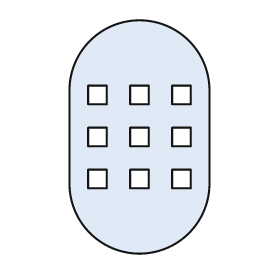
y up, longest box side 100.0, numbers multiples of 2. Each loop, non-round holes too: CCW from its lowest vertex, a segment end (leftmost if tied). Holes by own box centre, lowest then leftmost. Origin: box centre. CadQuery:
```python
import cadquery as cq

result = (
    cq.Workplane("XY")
    .moveTo(-30.0, -20.0)
    .threePointArc((0.0, -50.0), (30.0, -20.0))
    .lineTo(30.0, 20.0)
    .threePointArc((0.0, 50.0), (-30.0, 20.0))
    .close()
    .moveTo(-22.0, -22.0)
    .lineTo(-14.0, -22.0)
    .lineTo(-14.0, -14.0)
    .lineTo(-22.0, -14.0)
    .close()
    .moveTo(-4.0, -22.0)
    .lineTo(4.0, -22.0)
    .lineTo(4.0, -14.0)
    .lineTo(-4.0, -14.0)
    .close()
    .moveTo(14.0, -22.0)
    .lineTo(22.0, -22.0)
    .lineTo(22.0, -14.0)
    .lineTo(14.0, -14.0)
    .close()
    .moveTo(-22.0, -4.0)
    .lineTo(-14.0, -4.0)
    .lineTo(-14.0, 4.0)
    .lineTo(-22.0, 4.0)
    .close()
    .moveTo(-4.0, -4.0)
    .lineTo(4.0, -4.0)
    .lineTo(4.0, 4.0)
    .lineTo(-4.0, 4.0)
    .close()
    .moveTo(14.0, -4.0)
    .lineTo(22.0, -4.0)
    .lineTo(22.0, 4.0)
    .lineTo(14.0, 4.0)
    .close()
    .moveTo(-22.0, 14.0)
    .lineTo(-14.0, 14.0)
    .lineTo(-14.0, 22.0)
    .lineTo(-22.0, 22.0)
    .close()
    .moveTo(-4.0, 14.0)
    .lineTo(4.0, 14.0)
    .lineTo(4.0, 22.0)
    .lineTo(-4.0, 22.0)
    .close()
    .moveTo(14.0, 14.0)
    .lineTo(22.0, 14.0)
    .lineTo(22.0, 22.0)
    .lineTo(14.0, 22.0)
    .close()
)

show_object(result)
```